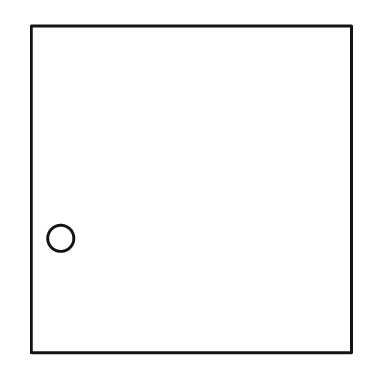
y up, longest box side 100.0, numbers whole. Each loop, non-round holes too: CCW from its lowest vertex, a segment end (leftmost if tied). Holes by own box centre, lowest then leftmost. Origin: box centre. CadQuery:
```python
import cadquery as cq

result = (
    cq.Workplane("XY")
    .moveTo(-49.0, -50.0)
    .lineTo(49.0, -50.0)
    .lineTo(49.0, 50.0)
    .lineTo(-49.0, 50.0)
    .close()
    .moveTo(-40.0, -15.0)
    .circle(4.0)
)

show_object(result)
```